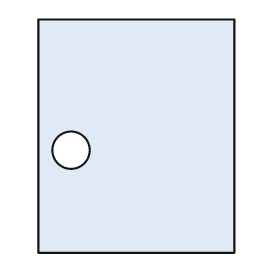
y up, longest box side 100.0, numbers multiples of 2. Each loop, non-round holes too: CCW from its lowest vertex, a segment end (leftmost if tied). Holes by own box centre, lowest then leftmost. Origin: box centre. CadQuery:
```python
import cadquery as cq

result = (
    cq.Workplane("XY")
    .moveTo(-42.0, -50.0)
    .lineTo(42.0, -50.0)
    .lineTo(42.0, 50.0)
    .lineTo(-42.0, 50.0)
    .close()
    .moveTo(-28.0, -6.0)
    .circle(8.0)
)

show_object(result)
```